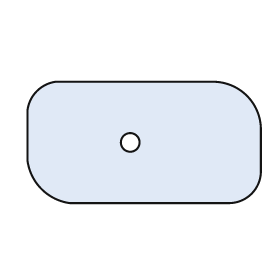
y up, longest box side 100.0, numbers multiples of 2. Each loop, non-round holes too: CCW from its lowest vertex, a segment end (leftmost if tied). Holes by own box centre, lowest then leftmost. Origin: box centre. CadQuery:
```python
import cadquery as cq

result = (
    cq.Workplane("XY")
    .moveTo(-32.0, -26.0)
    .lineTo(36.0, -26.0)
    .threePointArc((46.0, -22.0), (50.0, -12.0))
    .lineTo(50.0, 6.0)
    .threePointArc((44.0, 20.0), (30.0, 26.0))
    .lineTo(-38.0, 26.0)
    .threePointArc((-46.0, 22.0), (-50.0, 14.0))
    .lineTo(-50.0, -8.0)
    .threePointArc((-44.0, -20.0), (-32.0, -26.0))
    .close()
    .moveTo(-6.0, 0.0)
    .circle(4.0)
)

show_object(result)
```